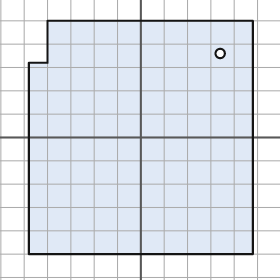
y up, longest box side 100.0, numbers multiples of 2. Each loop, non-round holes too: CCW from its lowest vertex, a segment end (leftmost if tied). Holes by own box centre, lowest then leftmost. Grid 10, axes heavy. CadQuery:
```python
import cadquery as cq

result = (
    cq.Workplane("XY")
    .moveTo(-48.0, -50.0)
    .lineTo(48.0, -50.0)
    .lineTo(48.0, 50.0)
    .lineTo(-40.0, 50.0)
    .lineTo(-40.0, 32.0)
    .lineTo(-48.0, 32.0)
    .close()
    .moveTo(34.0, 36.0)
    .circle(2.0)
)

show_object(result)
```